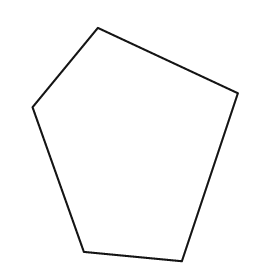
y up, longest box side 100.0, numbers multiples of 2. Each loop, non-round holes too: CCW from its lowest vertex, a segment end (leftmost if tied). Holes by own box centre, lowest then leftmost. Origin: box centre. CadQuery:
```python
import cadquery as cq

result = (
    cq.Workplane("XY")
    .moveTo(20.0, -50.0)
    .lineTo(44.0, 22.0)
    .lineTo(-16.0, 50.0)
    .lineTo(-44.0, 16.0)
    .lineTo(-22.0, -46.0)
    .close()
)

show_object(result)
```